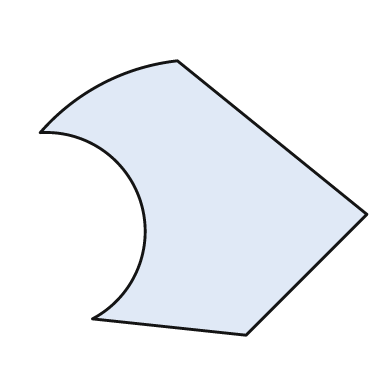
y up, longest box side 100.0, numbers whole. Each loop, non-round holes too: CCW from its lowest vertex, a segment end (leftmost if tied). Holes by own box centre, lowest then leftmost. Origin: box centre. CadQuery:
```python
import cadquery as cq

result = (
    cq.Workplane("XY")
    .moveTo(13.0, -42.0)
    .lineTo(50.0, -5.0)
    .lineTo(-8.0, 42.0)
    .threePointArc((-31.0, 35.0), (-50.0, 20.0))
    .threePointArc((-19.0, -2.0), (-34.0, -37.0))
    .close()
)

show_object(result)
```